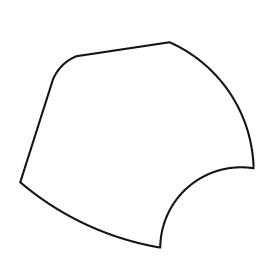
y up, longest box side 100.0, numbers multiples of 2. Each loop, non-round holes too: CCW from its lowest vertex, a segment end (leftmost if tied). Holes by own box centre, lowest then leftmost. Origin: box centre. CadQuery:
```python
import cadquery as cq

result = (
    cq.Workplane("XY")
    .moveTo(10.0, -44.0)
    .threePointArc((22.0, -18.0), (50.0, -10.0))
    .threePointArc((40.0, 22.0), (14.0, 44.0))
    .lineTo(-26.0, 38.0)
    .threePointArc((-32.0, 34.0), (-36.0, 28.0))
    .lineTo(-50.0, -16.0)
    .threePointArc((-22.0, -34.0), (10.0, -44.0))
    .close()
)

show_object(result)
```